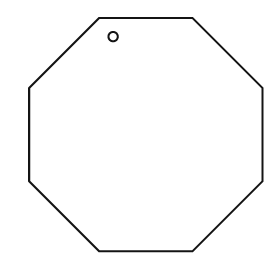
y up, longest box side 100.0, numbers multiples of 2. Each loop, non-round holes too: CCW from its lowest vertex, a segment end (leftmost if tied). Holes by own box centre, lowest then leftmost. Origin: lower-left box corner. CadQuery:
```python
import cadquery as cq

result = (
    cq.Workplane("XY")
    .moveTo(30.0, 0.0)
    .lineTo(70.0, 0.0)
    .lineTo(100.0, 30.0)
    .lineTo(100.0, 70.0)
    .lineTo(70.0, 100.0)
    .lineTo(30.0, 100.0)
    .lineTo(0.0, 70.0)
    .lineTo(0.0, 30.0)
    .close()
    .moveTo(36.0, 92.0)
    .circle(2.0)
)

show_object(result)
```